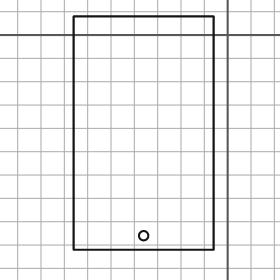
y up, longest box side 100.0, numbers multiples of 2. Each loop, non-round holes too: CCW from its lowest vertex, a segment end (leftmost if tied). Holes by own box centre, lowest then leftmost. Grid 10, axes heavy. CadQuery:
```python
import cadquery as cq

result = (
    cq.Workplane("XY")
    .moveTo(-66.0, -92.0)
    .lineTo(-6.0, -92.0)
    .lineTo(-6.0, 8.0)
    .lineTo(-66.0, 8.0)
    .close()
    .moveTo(-36.0, -86.0)
    .circle(2.0)
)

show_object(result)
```